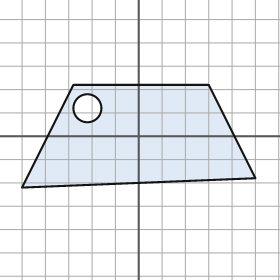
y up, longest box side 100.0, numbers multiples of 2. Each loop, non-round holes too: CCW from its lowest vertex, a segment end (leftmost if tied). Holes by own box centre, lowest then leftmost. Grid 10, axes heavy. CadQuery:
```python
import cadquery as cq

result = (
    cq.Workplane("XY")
    .moveTo(-50.0, -22.0)
    .lineTo(50.0, -18.0)
    .lineTo(30.0, 22.0)
    .lineTo(-28.0, 22.0)
    .close()
    .moveTo(-22.0, 12.0)
    .circle(6.0)
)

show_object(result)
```